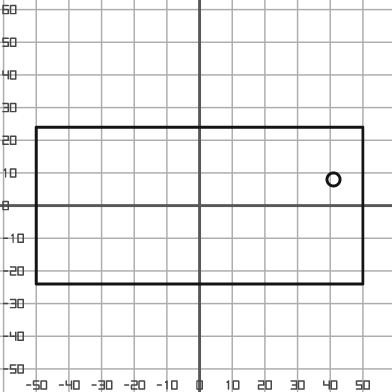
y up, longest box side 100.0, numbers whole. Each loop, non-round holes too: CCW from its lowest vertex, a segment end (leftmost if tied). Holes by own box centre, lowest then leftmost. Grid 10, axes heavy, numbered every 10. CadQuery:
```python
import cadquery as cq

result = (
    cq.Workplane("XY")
    .moveTo(-50.0, -24.0)
    .lineTo(50.0, -24.0)
    .lineTo(50.0, 24.0)
    .lineTo(-50.0, 24.0)
    .close()
    .moveTo(41.0, 8.0)
    .circle(2.0)
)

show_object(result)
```